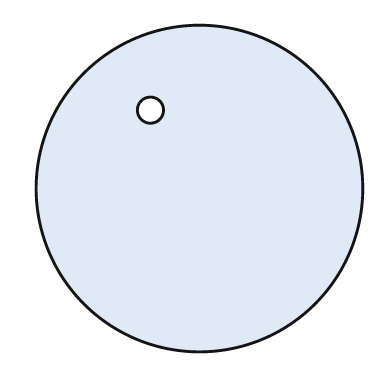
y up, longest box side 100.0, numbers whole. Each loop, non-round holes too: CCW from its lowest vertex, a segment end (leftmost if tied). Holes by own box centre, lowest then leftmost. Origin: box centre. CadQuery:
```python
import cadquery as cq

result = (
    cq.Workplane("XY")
    .moveTo(0.0, 0.0)
    .circle(50.0)
    .moveTo(-15.0, 24.0)
    .circle(4.0)
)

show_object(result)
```